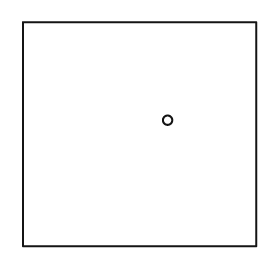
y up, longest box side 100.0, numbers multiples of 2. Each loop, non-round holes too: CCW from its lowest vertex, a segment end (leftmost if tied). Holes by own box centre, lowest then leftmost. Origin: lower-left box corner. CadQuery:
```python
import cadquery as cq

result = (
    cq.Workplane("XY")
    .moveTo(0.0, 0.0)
    .lineTo(100.0, 0.0)
    .lineTo(100.0, 96.0)
    .lineTo(0.0, 96.0)
    .close()
    .moveTo(62.0, 54.0)
    .circle(2.0)
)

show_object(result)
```